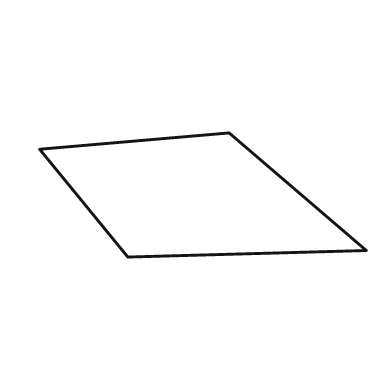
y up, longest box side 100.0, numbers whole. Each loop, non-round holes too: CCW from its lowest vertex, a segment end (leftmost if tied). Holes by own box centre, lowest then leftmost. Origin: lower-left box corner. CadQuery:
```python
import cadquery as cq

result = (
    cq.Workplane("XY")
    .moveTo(27.0, 0.0)
    .lineTo(100.0, 2.0)
    .lineTo(58.0, 38.0)
    .lineTo(0.0, 33.0)
    .close()
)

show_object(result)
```